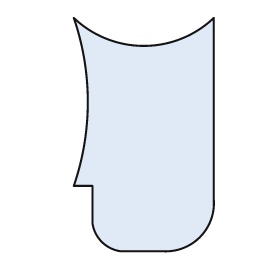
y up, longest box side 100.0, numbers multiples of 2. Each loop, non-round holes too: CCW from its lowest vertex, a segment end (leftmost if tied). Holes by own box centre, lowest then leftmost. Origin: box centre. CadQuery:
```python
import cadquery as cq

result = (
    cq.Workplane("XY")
    .moveTo(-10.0, -50.0)
    .lineTo(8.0, -50.0)
    .threePointArc((24.0, -44.0), (30.0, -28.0))
    .lineTo(30.0, 50.0)
    .threePointArc((0.0, 38.0), (-30.0, 50.0))
    .threePointArc((-24.0, 14.0), (-30.0, -22.0))
    .lineTo(-22.0, -22.0)
    .lineTo(-22.0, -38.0)
    .threePointArc((-18.0, -46.0), (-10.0, -50.0))
    .close()
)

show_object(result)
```